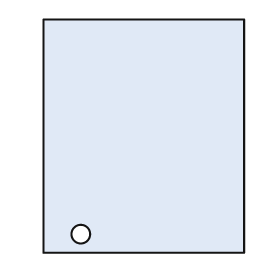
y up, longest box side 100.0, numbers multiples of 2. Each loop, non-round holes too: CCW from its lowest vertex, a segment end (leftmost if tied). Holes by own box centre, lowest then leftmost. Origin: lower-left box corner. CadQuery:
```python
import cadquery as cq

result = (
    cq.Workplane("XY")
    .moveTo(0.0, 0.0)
    .lineTo(86.0, 0.0)
    .lineTo(86.0, 100.0)
    .lineTo(0.0, 100.0)
    .close()
    .moveTo(16.0, 8.0)
    .circle(4.0)
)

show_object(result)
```